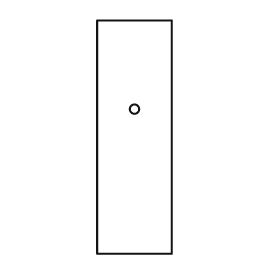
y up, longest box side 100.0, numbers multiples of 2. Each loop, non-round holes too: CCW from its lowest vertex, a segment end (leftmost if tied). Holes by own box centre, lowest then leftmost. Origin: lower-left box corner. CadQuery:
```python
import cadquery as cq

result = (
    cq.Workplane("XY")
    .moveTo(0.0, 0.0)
    .lineTo(32.0, 0.0)
    .lineTo(32.0, 100.0)
    .lineTo(0.0, 100.0)
    .close()
    .moveTo(16.0, 62.0)
    .circle(2.0)
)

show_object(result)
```